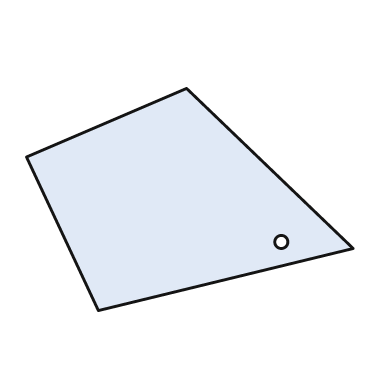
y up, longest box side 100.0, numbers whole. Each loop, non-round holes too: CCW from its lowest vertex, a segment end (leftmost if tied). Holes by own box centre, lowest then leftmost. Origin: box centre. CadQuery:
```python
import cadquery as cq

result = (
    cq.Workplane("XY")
    .moveTo(-28.0, -34.0)
    .lineTo(50.0, -15.0)
    .lineTo(-1.0, 34.0)
    .lineTo(-50.0, 13.0)
    .close()
    .moveTo(28.0, -13.0)
    .circle(2.0)
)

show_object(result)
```